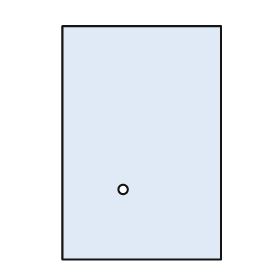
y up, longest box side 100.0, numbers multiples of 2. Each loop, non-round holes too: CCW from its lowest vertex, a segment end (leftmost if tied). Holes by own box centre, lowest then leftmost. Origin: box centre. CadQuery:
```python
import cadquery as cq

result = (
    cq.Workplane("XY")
    .moveTo(-34.0, -50.0)
    .lineTo(34.0, -50.0)
    .lineTo(34.0, 50.0)
    .lineTo(-34.0, 50.0)
    .close()
    .moveTo(-8.0, -20.0)
    .circle(2.0)
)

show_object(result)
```